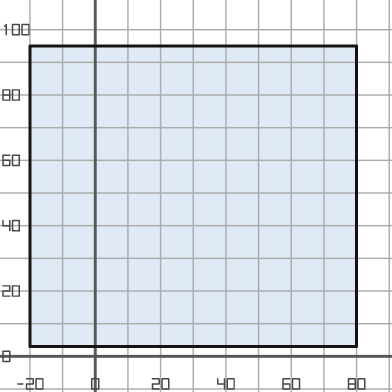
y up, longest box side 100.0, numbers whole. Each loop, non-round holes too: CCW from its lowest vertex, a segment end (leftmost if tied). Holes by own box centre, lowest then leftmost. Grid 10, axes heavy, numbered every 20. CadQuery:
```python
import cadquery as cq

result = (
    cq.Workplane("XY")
    .moveTo(-20.0, 3.0)
    .lineTo(80.0, 3.0)
    .lineTo(80.0, 95.0)
    .lineTo(-20.0, 95.0)
    .close()
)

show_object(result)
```